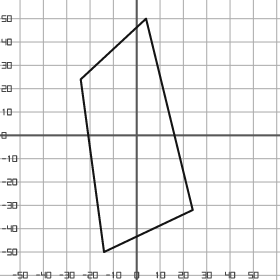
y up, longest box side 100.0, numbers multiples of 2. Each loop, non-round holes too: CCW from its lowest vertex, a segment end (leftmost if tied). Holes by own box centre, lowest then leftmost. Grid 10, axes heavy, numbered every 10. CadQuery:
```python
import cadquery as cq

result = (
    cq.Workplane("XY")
    .moveTo(-14.0, -50.0)
    .lineTo(24.0, -32.0)
    .lineTo(4.0, 50.0)
    .lineTo(-24.0, 24.0)
    .close()
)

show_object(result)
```